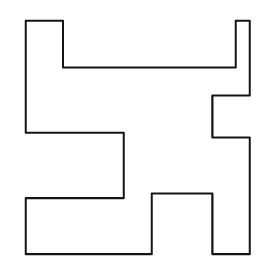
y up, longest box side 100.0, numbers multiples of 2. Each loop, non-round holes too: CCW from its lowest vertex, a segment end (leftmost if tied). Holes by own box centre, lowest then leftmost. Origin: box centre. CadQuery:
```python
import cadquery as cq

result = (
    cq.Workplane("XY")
    .moveTo(-48.0, -50.0)
    .lineTo(6.0, -50.0)
    .lineTo(6.0, -24.0)
    .lineTo(32.0, -24.0)
    .lineTo(32.0, -50.0)
    .lineTo(48.0, -50.0)
    .lineTo(48.0, 0.0)
    .lineTo(32.0, 0.0)
    .lineTo(32.0, 18.0)
    .lineTo(48.0, 18.0)
    .lineTo(48.0, 50.0)
    .lineTo(42.0, 50.0)
    .lineTo(42.0, 30.0)
    .lineTo(-32.0, 30.0)
    .lineTo(-32.0, 50.0)
    .lineTo(-48.0, 50.0)
    .lineTo(-48.0, 2.0)
    .lineTo(-6.0, 2.0)
    .lineTo(-6.0, -26.0)
    .lineTo(-48.0, -26.0)
    .close()
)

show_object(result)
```